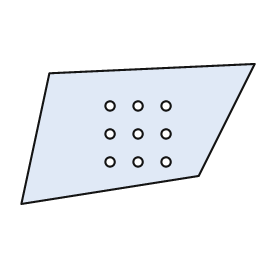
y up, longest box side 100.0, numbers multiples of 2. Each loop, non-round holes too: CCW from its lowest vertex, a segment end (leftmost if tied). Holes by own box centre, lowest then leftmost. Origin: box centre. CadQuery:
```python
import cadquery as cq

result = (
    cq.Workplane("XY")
    .moveTo(-50.0, -30.0)
    .lineTo(26.0, -18.0)
    .lineTo(50.0, 30.0)
    .lineTo(-38.0, 26.0)
    .close()
    .moveTo(-12.0, -12.0)
    .circle(2.0)
    .moveTo(0.0, -12.0)
    .circle(2.0)
    .moveTo(12.0, -12.0)
    .circle(2.0)
    .moveTo(-12.0, 0.0)
    .circle(2.0)
    .moveTo(0.0, 0.0)
    .circle(2.0)
    .moveTo(12.0, 0.0)
    .circle(2.0)
    .moveTo(-12.0, 12.0)
    .circle(2.0)
    .moveTo(0.0, 12.0)
    .circle(2.0)
    .moveTo(12.0, 12.0)
    .circle(2.0)
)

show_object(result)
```